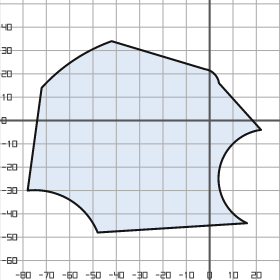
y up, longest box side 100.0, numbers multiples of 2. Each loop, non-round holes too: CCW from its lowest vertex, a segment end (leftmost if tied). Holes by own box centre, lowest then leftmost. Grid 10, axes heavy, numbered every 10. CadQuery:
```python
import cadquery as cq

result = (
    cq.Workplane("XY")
    .moveTo(-48.0, -48.0)
    .lineTo(16.0, -44.0)
    .threePointArc((4.0, -22.0), (22.0, -4.0))
    .lineTo(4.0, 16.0)
    .threePointArc((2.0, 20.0), (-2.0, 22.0))
    .lineTo(-42.0, 34.0)
    .threePointArc((-58.0, 26.0), (-72.0, 14.0))
    .lineTo(-78.0, -30.0)
    .threePointArc((-60.0, -34.0), (-48.0, -48.0))
    .close()
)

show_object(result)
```